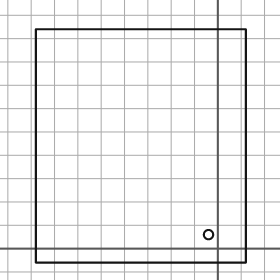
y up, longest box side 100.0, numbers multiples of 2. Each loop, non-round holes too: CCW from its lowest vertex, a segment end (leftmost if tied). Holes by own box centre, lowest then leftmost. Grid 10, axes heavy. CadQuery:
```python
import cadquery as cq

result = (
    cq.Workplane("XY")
    .moveTo(-78.0, -6.0)
    .lineTo(12.0, -6.0)
    .lineTo(12.0, 94.0)
    .lineTo(-78.0, 94.0)
    .close()
    .moveTo(-4.0, 6.0)
    .circle(2.0)
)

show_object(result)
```